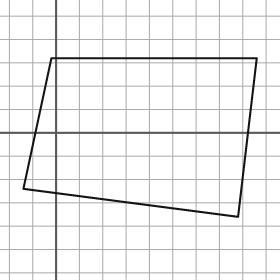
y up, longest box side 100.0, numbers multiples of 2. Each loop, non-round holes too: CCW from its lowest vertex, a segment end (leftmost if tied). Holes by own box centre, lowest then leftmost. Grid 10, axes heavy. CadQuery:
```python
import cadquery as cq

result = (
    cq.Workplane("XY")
    .moveTo(78.0, -36.0)
    .lineTo(86.0, 32.0)
    .lineTo(-2.0, 32.0)
    .lineTo(-14.0, -24.0)
    .close()
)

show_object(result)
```